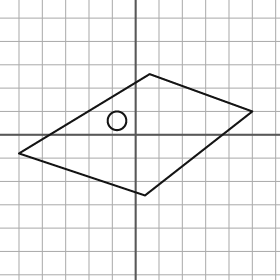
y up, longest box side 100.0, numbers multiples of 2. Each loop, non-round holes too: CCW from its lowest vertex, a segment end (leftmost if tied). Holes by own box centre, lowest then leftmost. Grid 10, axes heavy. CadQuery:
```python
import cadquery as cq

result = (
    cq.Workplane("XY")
    .moveTo(4.0, -26.0)
    .lineTo(50.0, 10.0)
    .lineTo(6.0, 26.0)
    .lineTo(-50.0, -8.0)
    .close()
    .moveTo(-8.0, 6.0)
    .circle(4.0)
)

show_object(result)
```